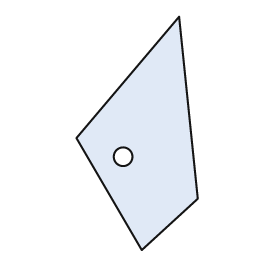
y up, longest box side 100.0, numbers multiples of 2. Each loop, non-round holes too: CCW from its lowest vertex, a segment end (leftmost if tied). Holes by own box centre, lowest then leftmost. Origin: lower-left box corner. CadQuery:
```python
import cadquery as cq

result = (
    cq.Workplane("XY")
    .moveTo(28.0, 0.0)
    .lineTo(52.0, 22.0)
    .lineTo(44.0, 100.0)
    .lineTo(0.0, 48.0)
    .close()
    .moveTo(20.0, 40.0)
    .circle(4.0)
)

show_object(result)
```